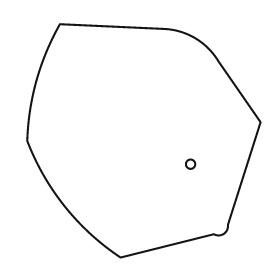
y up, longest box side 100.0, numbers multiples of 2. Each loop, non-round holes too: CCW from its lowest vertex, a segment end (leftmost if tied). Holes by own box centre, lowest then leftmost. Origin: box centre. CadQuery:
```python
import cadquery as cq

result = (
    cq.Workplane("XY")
    .moveTo(-10.0, -50.0)
    .lineTo(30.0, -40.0)
    .threePointArc((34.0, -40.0), (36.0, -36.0))
    .lineTo(50.0, 8.0)
    .lineTo(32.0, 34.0)
    .threePointArc((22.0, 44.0), (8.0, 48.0))
    .lineTo(-36.0, 50.0)
    .threePointArc((-46.0, 26.0), (-50.0, 0.0))
    .threePointArc((-34.0, -28.0), (-10.0, -50.0))
    .close()
    .moveTo(20.0, -10.0)
    .circle(2.0)
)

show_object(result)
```